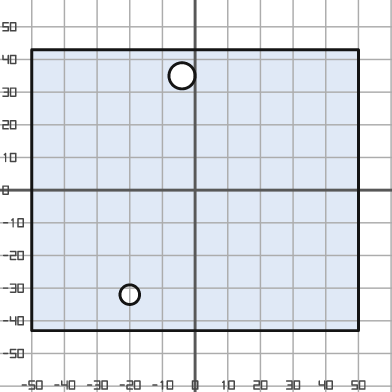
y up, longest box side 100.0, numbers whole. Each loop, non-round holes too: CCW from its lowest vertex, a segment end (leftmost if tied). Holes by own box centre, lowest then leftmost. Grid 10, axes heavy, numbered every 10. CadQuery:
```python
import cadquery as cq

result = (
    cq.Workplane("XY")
    .moveTo(-50.0, -43.0)
    .lineTo(50.0, -43.0)
    .lineTo(50.0, 43.0)
    .lineTo(-50.0, 43.0)
    .close()
    .moveTo(-20.0, -32.0)
    .circle(3.0)
    .moveTo(-4.0, 35.0)
    .circle(4.0)
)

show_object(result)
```